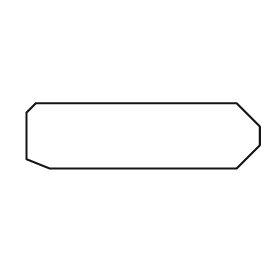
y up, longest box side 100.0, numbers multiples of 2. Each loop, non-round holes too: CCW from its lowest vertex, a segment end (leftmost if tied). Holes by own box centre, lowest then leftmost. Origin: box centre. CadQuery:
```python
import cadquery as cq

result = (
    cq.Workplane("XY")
    .moveTo(-40.0, -14.0)
    .lineTo(40.0, -14.0)
    .lineTo(50.0, -4.0)
    .lineTo(50.0, 4.0)
    .lineTo(40.0, 14.0)
    .lineTo(-46.0, 14.0)
    .lineTo(-50.0, 10.0)
    .lineTo(-50.0, -10.0)
    .close()
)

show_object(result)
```